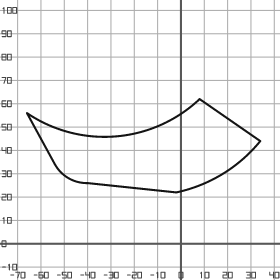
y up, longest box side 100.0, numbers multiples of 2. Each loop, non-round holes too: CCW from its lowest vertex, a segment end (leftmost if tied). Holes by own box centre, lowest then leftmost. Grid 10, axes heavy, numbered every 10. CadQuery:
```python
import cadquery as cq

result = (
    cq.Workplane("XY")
    .moveTo(-2.0, 22.0)
    .threePointArc((18.0, 30.0), (34.0, 44.0))
    .lineTo(8.0, 62.0)
    .threePointArc((-28.0, 46.0), (-66.0, 56.0))
    .lineTo(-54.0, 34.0)
    .threePointArc((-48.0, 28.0), (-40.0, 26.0))
    .close()
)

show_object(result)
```